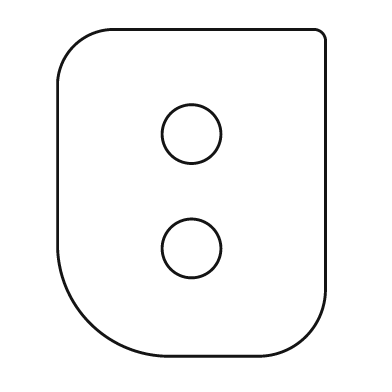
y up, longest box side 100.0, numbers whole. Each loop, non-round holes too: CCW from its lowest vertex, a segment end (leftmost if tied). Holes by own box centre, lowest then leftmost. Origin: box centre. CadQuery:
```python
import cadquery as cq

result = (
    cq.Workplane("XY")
    .moveTo(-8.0, -50.0)
    .lineTo(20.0, -50.0)
    .threePointArc((35.0, -44.0), (41.0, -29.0))
    .lineTo(41.0, 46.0)
    .threePointArc((40.0, 49.0), (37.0, 50.0))
    .lineTo(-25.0, 50.0)
    .threePointArc((-36.0, 45.0), (-41.0, 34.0))
    .lineTo(-41.0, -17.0)
    .threePointArc((-31.0, -40.0), (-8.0, -50.0))
    .close()
    .moveTo(0.0, -17.0)
    .circle(9.0)
    .moveTo(0.0, 18.0)
    .circle(9.0)
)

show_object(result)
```